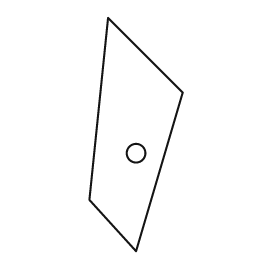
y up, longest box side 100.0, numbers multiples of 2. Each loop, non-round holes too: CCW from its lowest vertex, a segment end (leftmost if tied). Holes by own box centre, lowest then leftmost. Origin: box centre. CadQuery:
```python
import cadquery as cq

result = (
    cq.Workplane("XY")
    .moveTo(0.0, -50.0)
    .lineTo(20.0, 18.0)
    .lineTo(-12.0, 50.0)
    .lineTo(-20.0, -28.0)
    .close()
    .moveTo(0.0, -8.0)
    .circle(4.0)
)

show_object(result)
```